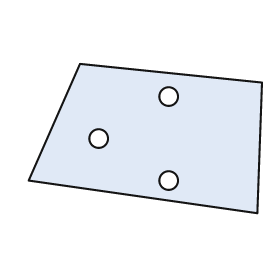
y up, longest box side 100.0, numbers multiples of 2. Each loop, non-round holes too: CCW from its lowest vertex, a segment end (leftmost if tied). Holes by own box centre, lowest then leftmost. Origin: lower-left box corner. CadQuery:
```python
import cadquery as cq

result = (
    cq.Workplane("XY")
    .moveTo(98.0, 0.0)
    .lineTo(100.0, 56.0)
    .lineTo(22.0, 64.0)
    .lineTo(0.0, 14.0)
    .close()
    .moveTo(60.0, 14.0)
    .circle(4.0)
    .moveTo(30.0, 32.0)
    .circle(4.0)
    .moveTo(60.0, 50.0)
    .circle(4.0)
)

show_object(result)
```